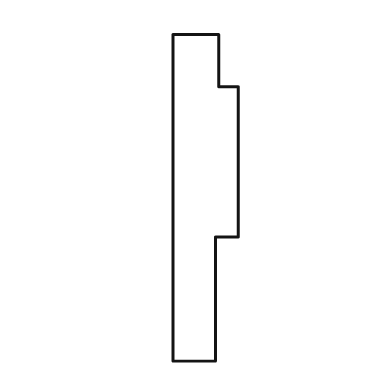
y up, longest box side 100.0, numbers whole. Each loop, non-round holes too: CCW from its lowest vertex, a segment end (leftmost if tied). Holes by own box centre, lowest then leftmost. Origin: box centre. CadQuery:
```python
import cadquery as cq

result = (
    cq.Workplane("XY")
    .moveTo(-10.0, -50.0)
    .lineTo(3.0, -50.0)
    .lineTo(3.0, -12.0)
    .lineTo(10.0, -12.0)
    .lineTo(10.0, 34.0)
    .lineTo(4.0, 34.0)
    .lineTo(4.0, 50.0)
    .lineTo(-10.0, 50.0)
    .close()
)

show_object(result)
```